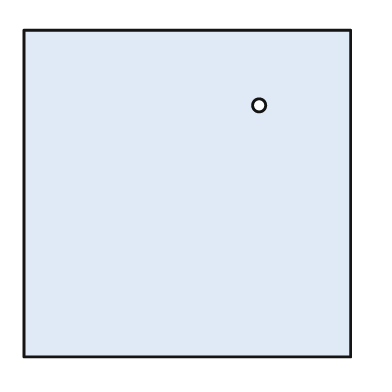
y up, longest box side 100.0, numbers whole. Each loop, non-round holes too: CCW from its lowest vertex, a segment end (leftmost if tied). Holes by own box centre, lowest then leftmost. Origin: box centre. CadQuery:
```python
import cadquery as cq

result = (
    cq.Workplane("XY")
    .moveTo(-50.0, -50.0)
    .lineTo(50.0, -50.0)
    .lineTo(50.0, 50.0)
    .lineTo(-50.0, 50.0)
    .close()
    .moveTo(22.0, 27.0)
    .circle(2.0)
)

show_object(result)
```